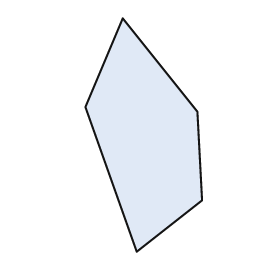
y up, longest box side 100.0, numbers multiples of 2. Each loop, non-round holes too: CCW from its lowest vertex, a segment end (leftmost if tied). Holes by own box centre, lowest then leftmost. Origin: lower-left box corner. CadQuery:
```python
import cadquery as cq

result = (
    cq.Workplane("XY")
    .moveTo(22.0, 0.0)
    .lineTo(50.0, 22.0)
    .lineTo(48.0, 60.0)
    .lineTo(16.0, 100.0)
    .lineTo(0.0, 62.0)
    .close()
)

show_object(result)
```